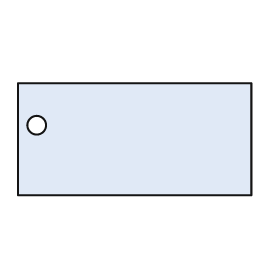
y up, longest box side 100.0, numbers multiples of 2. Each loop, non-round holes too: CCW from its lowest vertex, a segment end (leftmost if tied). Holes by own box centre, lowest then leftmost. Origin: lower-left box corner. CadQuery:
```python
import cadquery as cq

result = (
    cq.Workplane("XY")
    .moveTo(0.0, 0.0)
    .lineTo(100.0, 0.0)
    .lineTo(100.0, 48.0)
    .lineTo(0.0, 48.0)
    .close()
    .moveTo(8.0, 30.0)
    .circle(4.0)
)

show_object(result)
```